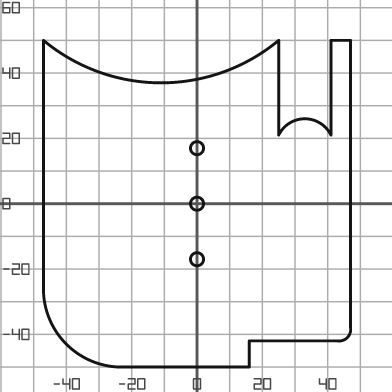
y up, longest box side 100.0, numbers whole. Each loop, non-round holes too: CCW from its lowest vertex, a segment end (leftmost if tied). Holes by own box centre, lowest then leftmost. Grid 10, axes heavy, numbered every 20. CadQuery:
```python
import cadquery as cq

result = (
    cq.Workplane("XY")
    .moveTo(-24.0, -50.0)
    .lineTo(16.0, -50.0)
    .lineTo(16.0, -42.0)
    .lineTo(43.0, -42.0)
    .threePointArc((46.0, -41.0), (47.0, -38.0))
    .lineTo(47.0, 50.0)
    .lineTo(41.0, 50.0)
    .lineTo(41.0, 21.0)
    .threePointArc((33.0, 26.0), (25.0, 21.0))
    .lineTo(25.0, 50.0)
    .threePointArc((-11.0, 37.0), (-47.0, 50.0))
    .lineTo(-47.0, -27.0)
    .threePointArc((-40.0, -43.0), (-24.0, -50.0))
    .close()
    .moveTo(0.0, -17.0)
    .circle(2.0)
    .moveTo(0.0, 0.0)
    .circle(2.0)
    .moveTo(0.0, 17.0)
    .circle(2.0)
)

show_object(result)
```